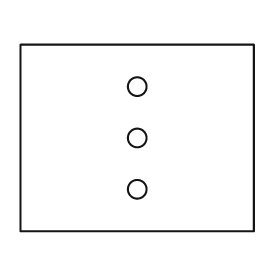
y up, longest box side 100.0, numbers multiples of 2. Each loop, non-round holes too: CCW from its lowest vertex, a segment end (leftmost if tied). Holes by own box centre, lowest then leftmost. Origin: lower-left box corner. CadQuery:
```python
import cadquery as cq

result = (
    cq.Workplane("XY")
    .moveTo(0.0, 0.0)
    .lineTo(100.0, 0.0)
    .lineTo(100.0, 80.0)
    .lineTo(0.0, 80.0)
    .close()
    .moveTo(50.0, 18.0)
    .circle(4.0)
    .moveTo(50.0, 40.0)
    .circle(4.0)
    .moveTo(50.0, 62.0)
    .circle(4.0)
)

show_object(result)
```